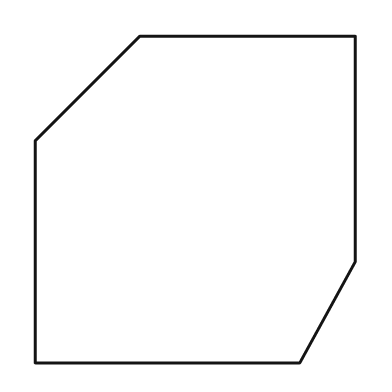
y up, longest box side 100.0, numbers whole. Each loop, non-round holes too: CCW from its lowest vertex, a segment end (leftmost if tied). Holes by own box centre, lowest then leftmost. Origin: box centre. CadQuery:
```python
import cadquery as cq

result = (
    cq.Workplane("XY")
    .moveTo(-49.0, -50.0)
    .lineTo(32.0, -50.0)
    .lineTo(49.0, -19.0)
    .lineTo(49.0, 50.0)
    .lineTo(-17.0, 50.0)
    .lineTo(-49.0, 18.0)
    .close()
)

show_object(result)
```